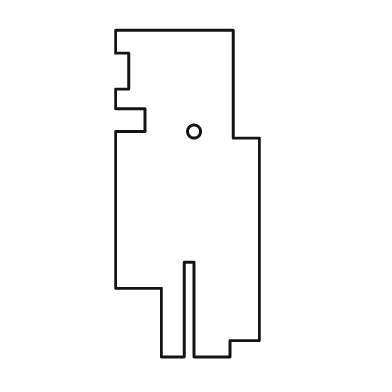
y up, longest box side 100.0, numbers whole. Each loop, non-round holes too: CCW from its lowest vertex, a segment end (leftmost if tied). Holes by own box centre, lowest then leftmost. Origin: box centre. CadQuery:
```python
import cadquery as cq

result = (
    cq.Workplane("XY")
    .moveTo(-8.0, -50.0)
    .lineTo(-1.0, -50.0)
    .lineTo(-1.0, -21.0)
    .lineTo(2.0, -21.0)
    .lineTo(2.0, -50.0)
    .lineTo(13.0, -50.0)
    .lineTo(13.0, -45.0)
    .lineTo(22.0, -45.0)
    .lineTo(22.0, 17.0)
    .lineTo(14.0, 17.0)
    .lineTo(14.0, 50.0)
    .lineTo(-22.0, 50.0)
    .lineTo(-22.0, 43.0)
    .lineTo(-18.0, 43.0)
    .lineTo(-18.0, 32.0)
    .lineTo(-22.0, 32.0)
    .lineTo(-22.0, 26.0)
    .lineTo(-13.0, 26.0)
    .lineTo(-13.0, 19.0)
    .lineTo(-22.0, 19.0)
    .lineTo(-22.0, -29.0)
    .lineTo(-8.0, -29.0)
    .close()
    .moveTo(2.0, 19.0)
    .circle(2.0)
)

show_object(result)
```